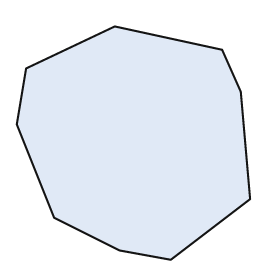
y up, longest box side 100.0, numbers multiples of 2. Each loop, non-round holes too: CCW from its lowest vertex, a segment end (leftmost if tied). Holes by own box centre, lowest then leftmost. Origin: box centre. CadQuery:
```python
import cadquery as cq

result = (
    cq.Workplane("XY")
    .moveTo(16.0, -50.0)
    .lineTo(50.0, -24.0)
    .lineTo(46.0, 22.0)
    .lineTo(38.0, 40.0)
    .lineTo(-8.0, 50.0)
    .lineTo(-46.0, 32.0)
    .lineTo(-50.0, 8.0)
    .lineTo(-34.0, -32.0)
    .lineTo(-6.0, -46.0)
    .close()
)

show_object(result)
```